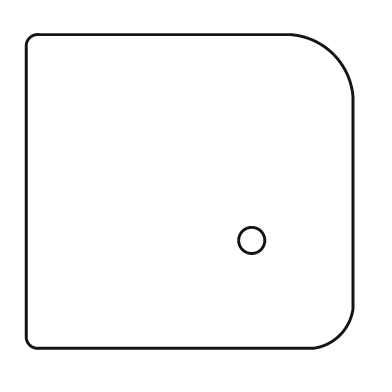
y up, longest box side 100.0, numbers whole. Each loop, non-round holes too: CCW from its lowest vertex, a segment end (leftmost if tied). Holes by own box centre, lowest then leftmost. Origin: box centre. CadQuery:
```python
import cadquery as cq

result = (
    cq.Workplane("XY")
    .moveTo(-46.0, -48.0)
    .lineTo(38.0, -48.0)
    .threePointArc((46.0, -44.0), (50.0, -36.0))
    .lineTo(50.0, 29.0)
    .threePointArc((44.0, 42.0), (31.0, 48.0))
    .lineTo(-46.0, 48.0)
    .threePointArc((-49.0, 47.0), (-50.0, 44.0))
    .lineTo(-50.0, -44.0)
    .threePointArc((-49.0, -47.0), (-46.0, -48.0))
    .close()
    .moveTo(19.0, -15.0)
    .circle(4.0)
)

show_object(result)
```